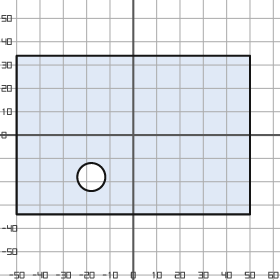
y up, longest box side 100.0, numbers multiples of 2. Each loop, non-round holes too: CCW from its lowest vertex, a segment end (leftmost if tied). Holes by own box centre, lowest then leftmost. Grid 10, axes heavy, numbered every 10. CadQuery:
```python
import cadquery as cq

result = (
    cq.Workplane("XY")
    .moveTo(-50.0, -34.0)
    .lineTo(50.0, -34.0)
    .lineTo(50.0, 34.0)
    .lineTo(-50.0, 34.0)
    .close()
    .moveTo(-18.0, -18.0)
    .circle(6.0)
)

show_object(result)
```